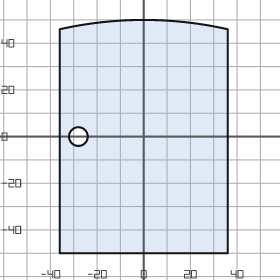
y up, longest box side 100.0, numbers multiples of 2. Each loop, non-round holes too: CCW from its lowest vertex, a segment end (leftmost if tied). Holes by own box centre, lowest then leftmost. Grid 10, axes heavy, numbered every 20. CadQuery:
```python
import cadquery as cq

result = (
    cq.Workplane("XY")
    .moveTo(-36.0, -50.0)
    .lineTo(36.0, -50.0)
    .lineTo(36.0, 46.0)
    .threePointArc((0.0, 50.0), (-36.0, 46.0))
    .close()
    .moveTo(-28.0, 0.0)
    .circle(4.0)
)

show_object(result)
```